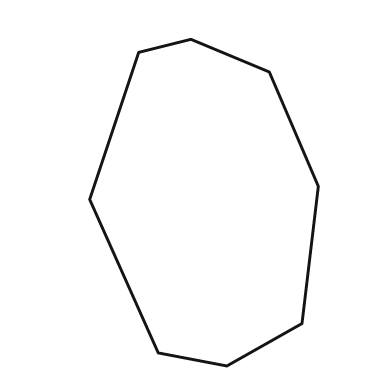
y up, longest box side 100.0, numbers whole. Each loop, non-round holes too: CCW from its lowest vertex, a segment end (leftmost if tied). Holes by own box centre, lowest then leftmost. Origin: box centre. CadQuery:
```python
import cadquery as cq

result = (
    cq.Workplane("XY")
    .moveTo(7.0, -50.0)
    .lineTo(30.0, -37.0)
    .lineTo(35.0, 5.0)
    .lineTo(20.0, 40.0)
    .lineTo(-4.0, 50.0)
    .lineTo(-20.0, 46.0)
    .lineTo(-35.0, 1.0)
    .lineTo(-14.0, -46.0)
    .close()
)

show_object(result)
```